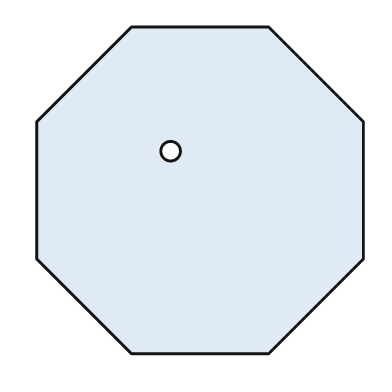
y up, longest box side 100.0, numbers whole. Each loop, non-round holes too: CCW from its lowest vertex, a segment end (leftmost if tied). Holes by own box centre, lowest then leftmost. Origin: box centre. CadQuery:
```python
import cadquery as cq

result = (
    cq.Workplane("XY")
    .moveTo(-21.0, -50.0)
    .lineTo(21.0, -50.0)
    .lineTo(50.0, -21.0)
    .lineTo(50.0, 21.0)
    .lineTo(21.0, 50.0)
    .lineTo(-21.0, 50.0)
    .lineTo(-50.0, 21.0)
    .lineTo(-50.0, -21.0)
    .close()
    .moveTo(-9.0, 12.0)
    .circle(3.0)
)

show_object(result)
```